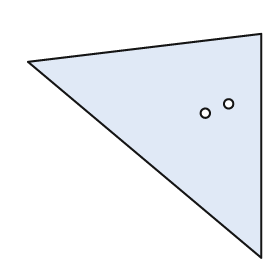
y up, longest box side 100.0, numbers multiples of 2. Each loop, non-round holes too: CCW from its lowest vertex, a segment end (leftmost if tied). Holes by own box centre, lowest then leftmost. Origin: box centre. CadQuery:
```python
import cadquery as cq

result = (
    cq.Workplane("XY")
    .moveTo(50.0, -48.0)
    .lineTo(50.0, 48.0)
    .lineTo(-50.0, 36.0)
    .close()
    .moveTo(26.0, 14.0)
    .circle(2.0)
    .moveTo(36.0, 18.0)
    .circle(2.0)
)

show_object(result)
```